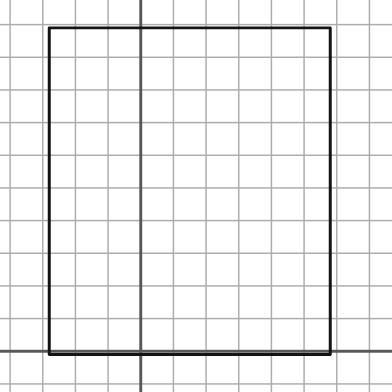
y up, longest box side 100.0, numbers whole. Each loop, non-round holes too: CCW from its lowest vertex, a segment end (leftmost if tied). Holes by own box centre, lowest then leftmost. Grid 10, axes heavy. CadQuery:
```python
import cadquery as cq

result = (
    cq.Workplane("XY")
    .moveTo(-28.0, -1.0)
    .lineTo(58.0, -1.0)
    .lineTo(58.0, 99.0)
    .lineTo(-28.0, 99.0)
    .close()
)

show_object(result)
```